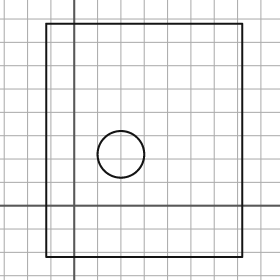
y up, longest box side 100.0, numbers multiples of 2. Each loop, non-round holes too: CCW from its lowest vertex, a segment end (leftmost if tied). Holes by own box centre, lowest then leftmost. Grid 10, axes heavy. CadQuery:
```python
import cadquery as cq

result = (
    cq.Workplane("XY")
    .moveTo(-12.0, -22.0)
    .lineTo(72.0, -22.0)
    .lineTo(72.0, 78.0)
    .lineTo(-12.0, 78.0)
    .close()
    .moveTo(20.0, 22.0)
    .circle(10.0)
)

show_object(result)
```